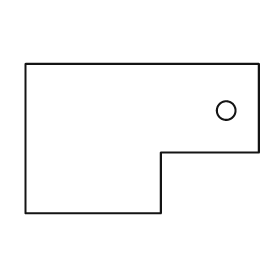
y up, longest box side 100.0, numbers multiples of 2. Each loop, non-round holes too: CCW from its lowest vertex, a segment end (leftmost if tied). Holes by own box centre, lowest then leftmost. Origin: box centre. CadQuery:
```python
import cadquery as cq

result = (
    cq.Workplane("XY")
    .moveTo(-50.0, -32.0)
    .lineTo(8.0, -32.0)
    .lineTo(8.0, -6.0)
    .lineTo(50.0, -6.0)
    .lineTo(50.0, 32.0)
    .lineTo(-50.0, 32.0)
    .close()
    .moveTo(36.0, 12.0)
    .circle(4.0)
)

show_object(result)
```